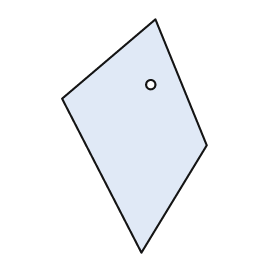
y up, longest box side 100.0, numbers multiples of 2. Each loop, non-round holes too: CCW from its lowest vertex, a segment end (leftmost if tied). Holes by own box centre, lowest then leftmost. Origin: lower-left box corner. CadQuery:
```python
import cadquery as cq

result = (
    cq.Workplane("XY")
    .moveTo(34.0, 0.0)
    .lineTo(62.0, 46.0)
    .lineTo(40.0, 100.0)
    .lineTo(0.0, 66.0)
    .close()
    .moveTo(38.0, 72.0)
    .circle(2.0)
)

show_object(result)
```